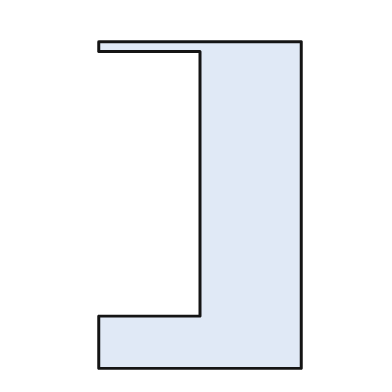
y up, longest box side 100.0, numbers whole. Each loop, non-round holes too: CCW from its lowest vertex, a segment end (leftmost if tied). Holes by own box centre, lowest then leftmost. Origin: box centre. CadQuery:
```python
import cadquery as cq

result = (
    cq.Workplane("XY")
    .moveTo(-31.0, -50.0)
    .lineTo(31.0, -50.0)
    .lineTo(31.0, 50.0)
    .lineTo(-31.0, 50.0)
    .lineTo(-31.0, 47.0)
    .lineTo(0.0, 47.0)
    .lineTo(0.0, -34.0)
    .lineTo(-31.0, -34.0)
    .close()
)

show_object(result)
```